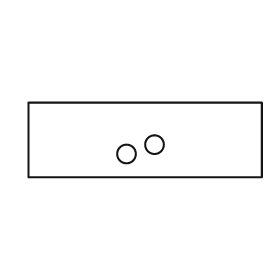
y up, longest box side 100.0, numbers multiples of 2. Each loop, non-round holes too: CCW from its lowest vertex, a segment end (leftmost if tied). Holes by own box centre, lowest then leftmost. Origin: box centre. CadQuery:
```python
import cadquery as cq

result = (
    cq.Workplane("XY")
    .moveTo(-50.0, -16.0)
    .lineTo(50.0, -16.0)
    .lineTo(50.0, 16.0)
    .lineTo(-50.0, 16.0)
    .close()
    .moveTo(-8.0, -6.0)
    .circle(4.0)
    .moveTo(4.0, -2.0)
    .circle(4.0)
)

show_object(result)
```